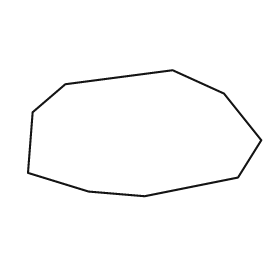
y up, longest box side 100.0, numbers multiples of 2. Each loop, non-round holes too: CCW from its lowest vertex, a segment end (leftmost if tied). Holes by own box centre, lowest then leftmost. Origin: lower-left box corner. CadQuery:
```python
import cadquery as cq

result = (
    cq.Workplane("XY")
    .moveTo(50.0, 0.0)
    .lineTo(90.0, 8.0)
    .lineTo(100.0, 24.0)
    .lineTo(84.0, 44.0)
    .lineTo(62.0, 54.0)
    .lineTo(16.0, 48.0)
    .lineTo(2.0, 36.0)
    .lineTo(0.0, 10.0)
    .lineTo(26.0, 2.0)
    .close()
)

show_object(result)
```